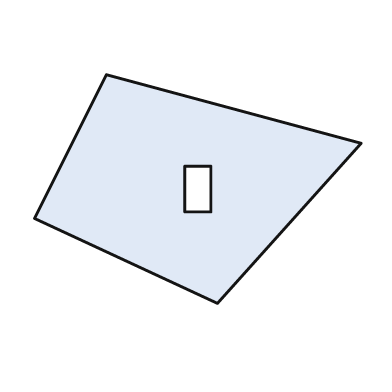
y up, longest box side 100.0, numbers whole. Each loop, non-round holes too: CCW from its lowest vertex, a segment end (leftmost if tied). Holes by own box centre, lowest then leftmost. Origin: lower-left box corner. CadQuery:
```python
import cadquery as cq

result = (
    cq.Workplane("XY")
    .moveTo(56.0, 0.0)
    .lineTo(100.0, 49.0)
    .lineTo(22.0, 70.0)
    .lineTo(0.0, 26.0)
    .close()
    .moveTo(46.0, 28.0)
    .lineTo(54.0, 28.0)
    .lineTo(54.0, 42.0)
    .lineTo(46.0, 42.0)
    .close()
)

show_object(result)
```